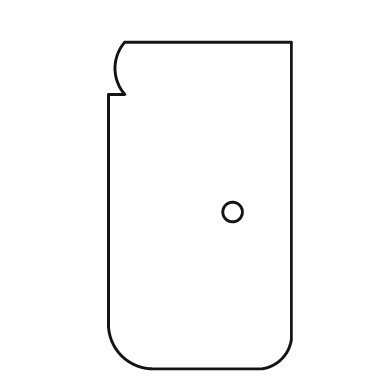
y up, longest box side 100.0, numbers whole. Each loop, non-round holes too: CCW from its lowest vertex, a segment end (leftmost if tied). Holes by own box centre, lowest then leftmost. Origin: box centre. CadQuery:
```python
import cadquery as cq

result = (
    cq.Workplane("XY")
    .moveTo(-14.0, -50.0)
    .lineTo(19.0, -50.0)
    .threePointArc((25.0, -47.0), (28.0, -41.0))
    .lineTo(28.0, 50.0)
    .lineTo(-23.0, 50.0)
    .threePointArc((-26.0, 42.0), (-23.0, 34.0))
    .lineTo(-28.0, 34.0)
    .lineTo(-28.0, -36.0)
    .threePointArc((-24.0, -46.0), (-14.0, -50.0))
    .close()
    .moveTo(10.0, -2.0)
    .circle(3.0)
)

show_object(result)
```